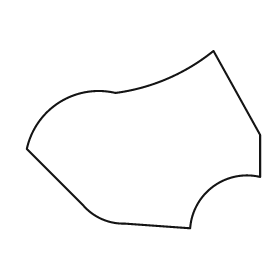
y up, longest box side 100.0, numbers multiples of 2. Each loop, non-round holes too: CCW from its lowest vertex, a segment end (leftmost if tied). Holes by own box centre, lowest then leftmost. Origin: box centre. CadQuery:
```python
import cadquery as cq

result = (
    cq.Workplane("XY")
    .moveTo(20.0, -38.0)
    .threePointArc((30.0, -20.0), (50.0, -16.0))
    .lineTo(50.0, 2.0)
    .lineTo(30.0, 38.0)
    .threePointArc((10.0, 26.0), (-12.0, 20.0))
    .threePointArc((-36.0, 16.0), (-50.0, -4.0))
    .lineTo(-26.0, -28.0)
    .threePointArc((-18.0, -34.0), (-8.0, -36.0))
    .close()
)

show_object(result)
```